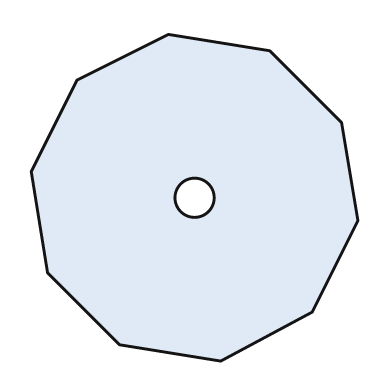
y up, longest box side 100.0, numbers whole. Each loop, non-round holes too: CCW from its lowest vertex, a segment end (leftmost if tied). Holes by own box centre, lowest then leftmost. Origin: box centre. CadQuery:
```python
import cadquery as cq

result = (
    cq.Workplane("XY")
    .moveTo(8.0, -50.0)
    .lineTo(36.0, -35.0)
    .lineTo(50.0, -7.0)
    .lineTo(45.0, 23.0)
    .lineTo(23.0, 45.0)
    .lineTo(-8.0, 50.0)
    .lineTo(-36.0, 36.0)
    .lineTo(-50.0, 8.0)
    .lineTo(-45.0, -23.0)
    .lineTo(-23.0, -45.0)
    .close()
    .moveTo(0.0, 0.0)
    .circle(6.0)
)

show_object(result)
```